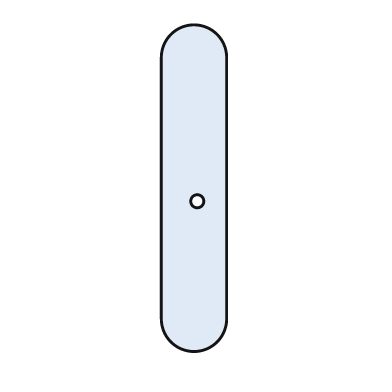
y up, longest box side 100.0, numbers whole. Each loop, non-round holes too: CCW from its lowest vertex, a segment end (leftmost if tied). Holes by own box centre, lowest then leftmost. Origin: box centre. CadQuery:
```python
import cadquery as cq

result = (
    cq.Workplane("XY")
    .moveTo(-10.0, -40.0)
    .threePointArc((0.0, -50.0), (10.0, -40.0))
    .lineTo(10.0, 40.0)
    .threePointArc((0.0, 50.0), (-10.0, 40.0))
    .close()
    .moveTo(1.0, -4.0)
    .circle(2.0)
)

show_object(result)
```